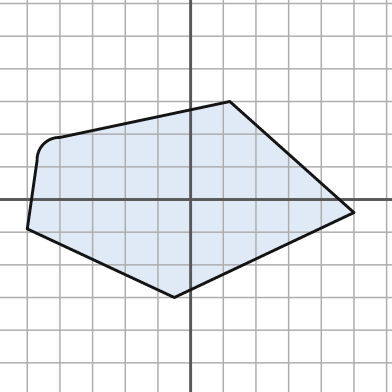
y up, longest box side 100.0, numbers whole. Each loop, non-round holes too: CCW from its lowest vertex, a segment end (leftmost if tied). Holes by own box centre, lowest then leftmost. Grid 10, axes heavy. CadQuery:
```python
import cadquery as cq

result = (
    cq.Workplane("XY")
    .moveTo(-5.0, -30.0)
    .lineTo(50.0, -4.0)
    .lineTo(12.0, 30.0)
    .lineTo(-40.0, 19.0)
    .threePointArc((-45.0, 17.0), (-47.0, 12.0))
    .lineTo(-50.0, -9.0)
    .close()
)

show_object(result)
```